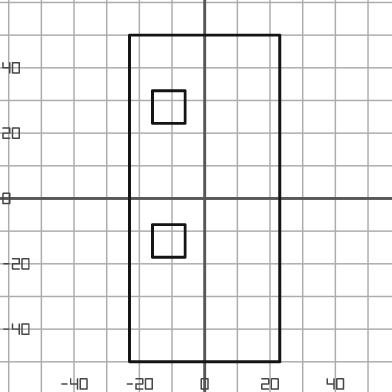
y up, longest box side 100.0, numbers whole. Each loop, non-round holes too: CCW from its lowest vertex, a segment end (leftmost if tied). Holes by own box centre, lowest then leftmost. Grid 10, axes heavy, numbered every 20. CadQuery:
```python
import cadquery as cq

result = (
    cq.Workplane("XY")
    .moveTo(-23.0, -50.0)
    .lineTo(23.0, -50.0)
    .lineTo(23.0, 50.0)
    .lineTo(-23.0, 50.0)
    .close()
    .moveTo(-16.0, -18.0)
    .lineTo(-6.0, -18.0)
    .lineTo(-6.0, -8.0)
    .lineTo(-16.0, -8.0)
    .close()
    .moveTo(-16.0, 23.0)
    .lineTo(-6.0, 23.0)
    .lineTo(-6.0, 33.0)
    .lineTo(-16.0, 33.0)
    .close()
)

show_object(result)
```